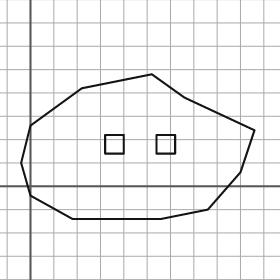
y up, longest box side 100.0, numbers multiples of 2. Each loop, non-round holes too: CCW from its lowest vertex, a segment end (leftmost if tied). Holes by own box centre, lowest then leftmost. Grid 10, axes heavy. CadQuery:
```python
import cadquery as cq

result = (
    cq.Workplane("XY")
    .moveTo(18.0, -14.0)
    .lineTo(56.0, -14.0)
    .lineTo(76.0, -10.0)
    .lineTo(90.0, 6.0)
    .lineTo(96.0, 24.0)
    .lineTo(66.0, 38.0)
    .lineTo(52.0, 48.0)
    .lineTo(22.0, 42.0)
    .lineTo(0.0, 26.0)
    .lineTo(-4.0, 10.0)
    .lineTo(0.0, -4.0)
    .close()
    .moveTo(32.0, 14.0)
    .lineTo(40.0, 14.0)
    .lineTo(40.0, 22.0)
    .lineTo(32.0, 22.0)
    .close()
    .moveTo(54.0, 14.0)
    .lineTo(62.0, 14.0)
    .lineTo(62.0, 22.0)
    .lineTo(54.0, 22.0)
    .close()
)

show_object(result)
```